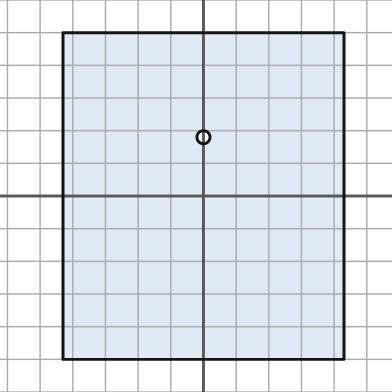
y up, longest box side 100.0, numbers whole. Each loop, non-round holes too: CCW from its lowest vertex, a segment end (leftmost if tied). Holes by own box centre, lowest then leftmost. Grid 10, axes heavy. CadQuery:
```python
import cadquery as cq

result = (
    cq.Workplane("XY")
    .moveTo(-43.0, -50.0)
    .lineTo(43.0, -50.0)
    .lineTo(43.0, 50.0)
    .lineTo(-43.0, 50.0)
    .close()
    .moveTo(0.0, 18.0)
    .circle(2.0)
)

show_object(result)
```